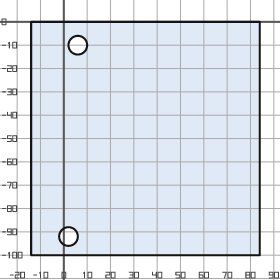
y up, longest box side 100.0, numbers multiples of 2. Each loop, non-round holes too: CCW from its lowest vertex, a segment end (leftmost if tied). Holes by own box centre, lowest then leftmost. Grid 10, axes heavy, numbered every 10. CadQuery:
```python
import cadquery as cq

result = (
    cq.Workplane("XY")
    .moveTo(-14.0, -100.0)
    .lineTo(84.0, -100.0)
    .lineTo(84.0, 0.0)
    .lineTo(-14.0, 0.0)
    .close()
    .moveTo(2.0, -92.0)
    .circle(4.0)
    .moveTo(6.0, -10.0)
    .circle(4.0)
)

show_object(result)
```